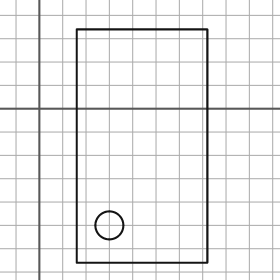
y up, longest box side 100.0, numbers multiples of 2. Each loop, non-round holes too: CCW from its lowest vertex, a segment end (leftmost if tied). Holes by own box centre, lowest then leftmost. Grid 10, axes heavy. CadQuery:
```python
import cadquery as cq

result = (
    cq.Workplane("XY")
    .moveTo(16.0, -66.0)
    .lineTo(72.0, -66.0)
    .lineTo(72.0, 34.0)
    .lineTo(16.0, 34.0)
    .close()
    .moveTo(30.0, -50.0)
    .circle(6.0)
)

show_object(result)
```